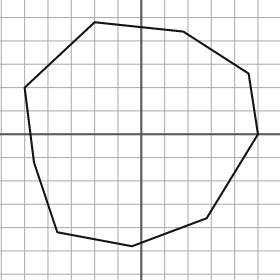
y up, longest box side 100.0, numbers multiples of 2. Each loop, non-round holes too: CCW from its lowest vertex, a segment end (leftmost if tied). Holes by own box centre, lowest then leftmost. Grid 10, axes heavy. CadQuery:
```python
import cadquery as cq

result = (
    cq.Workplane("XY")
    .moveTo(-4.0, -48.0)
    .lineTo(28.0, -36.0)
    .lineTo(50.0, 0.0)
    .lineTo(46.0, 26.0)
    .lineTo(18.0, 44.0)
    .lineTo(-20.0, 48.0)
    .lineTo(-50.0, 20.0)
    .lineTo(-46.0, -12.0)
    .lineTo(-36.0, -42.0)
    .close()
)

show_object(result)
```